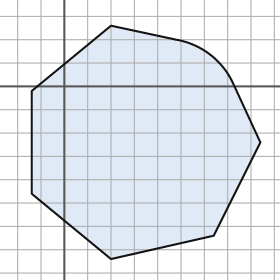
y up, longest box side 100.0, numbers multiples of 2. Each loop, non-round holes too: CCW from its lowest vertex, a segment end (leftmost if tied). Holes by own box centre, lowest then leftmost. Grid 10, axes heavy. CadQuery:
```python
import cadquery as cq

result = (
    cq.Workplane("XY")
    .moveTo(20.0, -74.0)
    .lineTo(64.0, -64.0)
    .lineTo(84.0, -24.0)
    .lineTo(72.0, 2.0)
    .threePointArc((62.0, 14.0), (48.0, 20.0))
    .lineTo(20.0, 26.0)
    .lineTo(-14.0, -2.0)
    .lineTo(-14.0, -46.0)
    .close()
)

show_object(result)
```